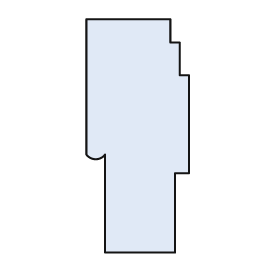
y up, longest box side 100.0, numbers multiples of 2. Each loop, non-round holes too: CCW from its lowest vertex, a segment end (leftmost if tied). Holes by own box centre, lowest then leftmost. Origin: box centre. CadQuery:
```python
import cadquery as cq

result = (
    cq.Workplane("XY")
    .moveTo(-14.0, -50.0)
    .lineTo(16.0, -50.0)
    .lineTo(16.0, -16.0)
    .lineTo(22.0, -16.0)
    .lineTo(22.0, 26.0)
    .lineTo(18.0, 26.0)
    .lineTo(18.0, 40.0)
    .lineTo(14.0, 40.0)
    .lineTo(14.0, 50.0)
    .lineTo(-22.0, 50.0)
    .lineTo(-22.0, -8.0)
    .threePointArc((-18.0, -10.0), (-14.0, -8.0))
    .close()
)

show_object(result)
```